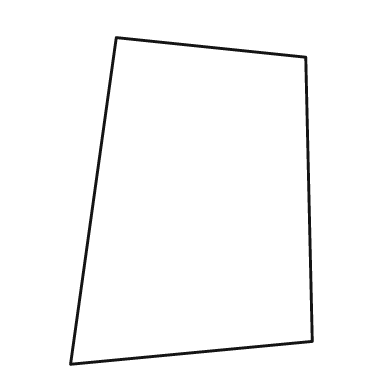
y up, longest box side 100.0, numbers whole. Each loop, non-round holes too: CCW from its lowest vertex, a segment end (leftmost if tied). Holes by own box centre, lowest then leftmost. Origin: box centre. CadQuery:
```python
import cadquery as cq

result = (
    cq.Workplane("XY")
    .moveTo(-37.0, -50.0)
    .lineTo(37.0, -43.0)
    .lineTo(35.0, 44.0)
    .lineTo(-23.0, 50.0)
    .close()
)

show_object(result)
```